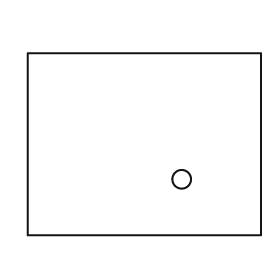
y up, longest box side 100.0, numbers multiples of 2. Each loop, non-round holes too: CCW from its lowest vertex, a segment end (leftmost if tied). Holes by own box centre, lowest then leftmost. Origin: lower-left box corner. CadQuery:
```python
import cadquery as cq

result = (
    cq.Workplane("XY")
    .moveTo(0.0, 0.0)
    .lineTo(100.0, 0.0)
    .lineTo(100.0, 78.0)
    .lineTo(0.0, 78.0)
    .close()
    .moveTo(66.0, 24.0)
    .circle(4.0)
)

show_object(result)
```